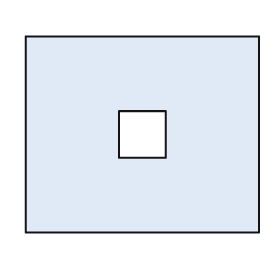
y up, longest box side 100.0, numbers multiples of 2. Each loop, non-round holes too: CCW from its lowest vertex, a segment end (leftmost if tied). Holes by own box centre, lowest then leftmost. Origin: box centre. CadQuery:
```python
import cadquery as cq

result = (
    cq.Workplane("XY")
    .moveTo(-50.0, -42.0)
    .lineTo(50.0, -42.0)
    .lineTo(50.0, 42.0)
    .lineTo(-50.0, 42.0)
    .close()
    .moveTo(-10.0, -10.0)
    .lineTo(10.0, -10.0)
    .lineTo(10.0, 10.0)
    .lineTo(-10.0, 10.0)
    .close()
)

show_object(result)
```